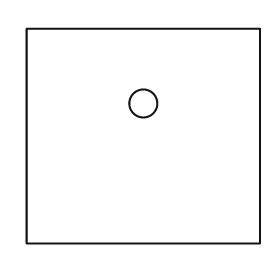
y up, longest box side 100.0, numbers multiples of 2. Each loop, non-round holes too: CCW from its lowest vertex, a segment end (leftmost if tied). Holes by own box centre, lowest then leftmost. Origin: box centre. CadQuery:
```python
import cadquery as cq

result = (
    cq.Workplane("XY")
    .moveTo(-50.0, -46.0)
    .lineTo(50.0, -46.0)
    .lineTo(50.0, 46.0)
    .lineTo(-50.0, 46.0)
    .close()
    .moveTo(0.0, 14.0)
    .circle(6.0)
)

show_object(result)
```